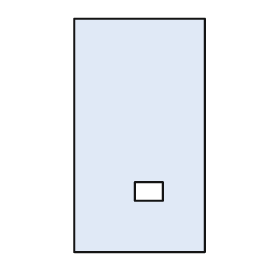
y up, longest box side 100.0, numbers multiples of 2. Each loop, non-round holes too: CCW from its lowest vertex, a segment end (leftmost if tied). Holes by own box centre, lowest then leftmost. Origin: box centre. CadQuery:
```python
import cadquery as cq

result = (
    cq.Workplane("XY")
    .moveTo(-28.0, -50.0)
    .lineTo(28.0, -50.0)
    .lineTo(28.0, 50.0)
    .lineTo(-28.0, 50.0)
    .close()
    .moveTo(-2.0, -28.0)
    .lineTo(10.0, -28.0)
    .lineTo(10.0, -20.0)
    .lineTo(-2.0, -20.0)
    .close()
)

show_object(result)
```